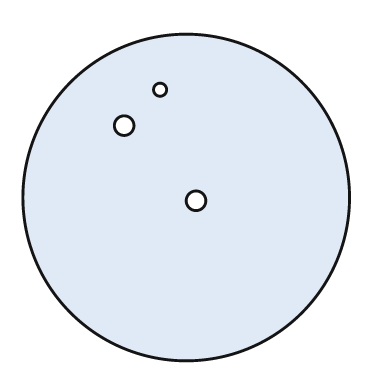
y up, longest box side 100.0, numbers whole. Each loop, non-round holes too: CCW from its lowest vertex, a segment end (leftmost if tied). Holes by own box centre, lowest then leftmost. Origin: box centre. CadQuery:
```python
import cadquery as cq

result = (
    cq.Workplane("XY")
    .moveTo(0.0, 0.0)
    .circle(50.0)
    .moveTo(3.0, -1.0)
    .circle(3.0)
    .moveTo(-19.0, 22.0)
    .circle(3.0)
    .moveTo(-8.0, 33.0)
    .circle(2.0)
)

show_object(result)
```